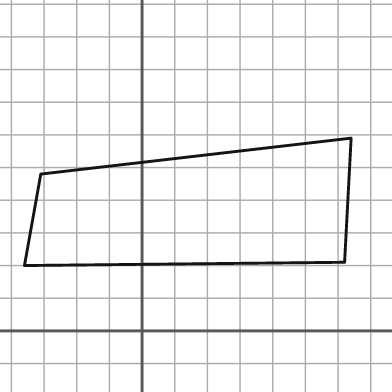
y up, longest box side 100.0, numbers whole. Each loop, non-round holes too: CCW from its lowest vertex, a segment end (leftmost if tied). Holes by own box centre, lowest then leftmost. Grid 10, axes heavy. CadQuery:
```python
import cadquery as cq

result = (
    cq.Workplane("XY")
    .moveTo(-36.0, 20.0)
    .lineTo(62.0, 21.0)
    .lineTo(64.0, 59.0)
    .lineTo(-31.0, 48.0)
    .close()
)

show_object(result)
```